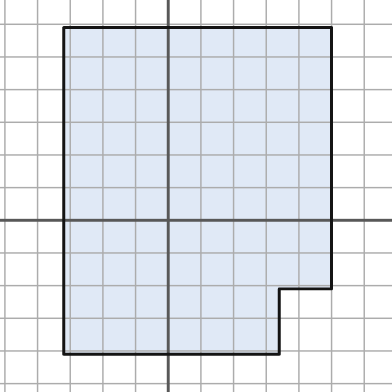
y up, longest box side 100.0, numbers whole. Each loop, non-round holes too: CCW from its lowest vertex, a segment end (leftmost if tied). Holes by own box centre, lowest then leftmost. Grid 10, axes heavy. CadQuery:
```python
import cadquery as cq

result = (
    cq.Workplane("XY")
    .moveTo(-32.0, -41.0)
    .lineTo(34.0, -41.0)
    .lineTo(34.0, -21.0)
    .lineTo(50.0, -21.0)
    .lineTo(50.0, 59.0)
    .lineTo(-32.0, 59.0)
    .close()
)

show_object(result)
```